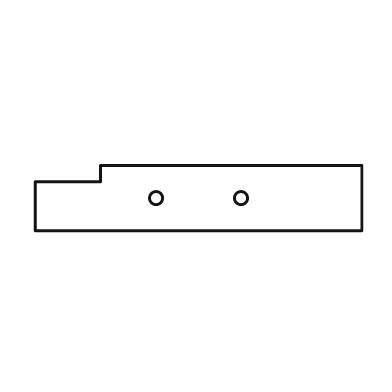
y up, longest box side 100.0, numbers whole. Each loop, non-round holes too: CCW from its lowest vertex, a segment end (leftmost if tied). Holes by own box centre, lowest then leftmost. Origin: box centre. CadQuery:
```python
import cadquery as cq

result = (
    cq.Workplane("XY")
    .moveTo(-50.0, -10.0)
    .lineTo(50.0, -10.0)
    .lineTo(50.0, 10.0)
    .lineTo(-30.0, 10.0)
    .lineTo(-30.0, 5.0)
    .lineTo(-50.0, 5.0)
    .close()
    .moveTo(-13.0, 0.0)
    .circle(2.0)
    .moveTo(13.0, 0.0)
    .circle(2.0)
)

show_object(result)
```